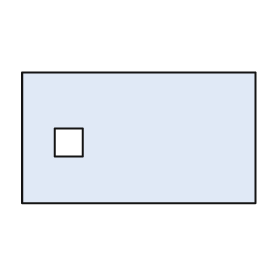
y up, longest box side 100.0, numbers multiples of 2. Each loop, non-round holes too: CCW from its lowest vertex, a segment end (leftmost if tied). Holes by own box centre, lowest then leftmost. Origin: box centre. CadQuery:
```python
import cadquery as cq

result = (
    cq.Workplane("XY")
    .moveTo(-50.0, -28.0)
    .lineTo(50.0, -28.0)
    .lineTo(50.0, 28.0)
    .lineTo(-50.0, 28.0)
    .close()
    .moveTo(-36.0, -8.0)
    .lineTo(-24.0, -8.0)
    .lineTo(-24.0, 4.0)
    .lineTo(-36.0, 4.0)
    .close()
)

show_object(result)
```